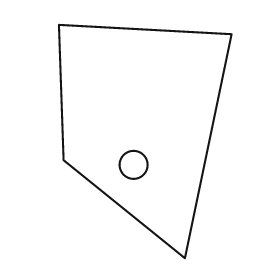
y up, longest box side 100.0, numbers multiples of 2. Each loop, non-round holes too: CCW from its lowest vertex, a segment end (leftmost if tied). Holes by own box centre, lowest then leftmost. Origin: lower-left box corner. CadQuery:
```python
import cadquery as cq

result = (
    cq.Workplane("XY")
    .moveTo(54.0, 0.0)
    .lineTo(74.0, 96.0)
    .lineTo(0.0, 100.0)
    .lineTo(2.0, 42.0)
    .close()
    .moveTo(32.0, 40.0)
    .circle(6.0)
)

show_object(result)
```